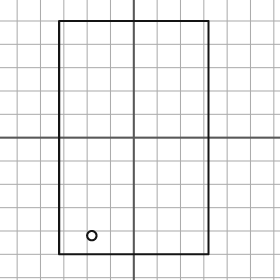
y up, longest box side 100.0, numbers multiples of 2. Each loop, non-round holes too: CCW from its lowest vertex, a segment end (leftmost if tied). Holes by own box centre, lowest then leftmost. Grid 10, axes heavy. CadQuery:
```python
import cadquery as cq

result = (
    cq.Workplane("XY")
    .moveTo(-32.0, -50.0)
    .lineTo(32.0, -50.0)
    .lineTo(32.0, 50.0)
    .lineTo(-32.0, 50.0)
    .close()
    .moveTo(-18.0, -42.0)
    .circle(2.0)
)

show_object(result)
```